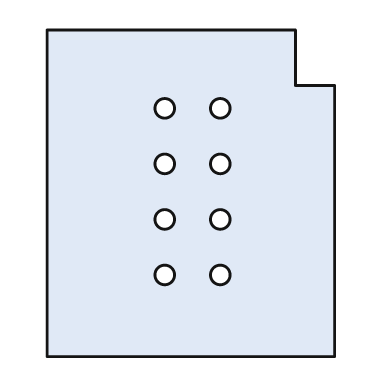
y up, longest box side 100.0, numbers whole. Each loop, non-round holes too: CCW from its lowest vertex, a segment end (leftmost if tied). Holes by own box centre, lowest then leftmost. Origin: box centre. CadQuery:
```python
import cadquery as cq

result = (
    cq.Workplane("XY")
    .moveTo(-44.0, -50.0)
    .lineTo(44.0, -50.0)
    .lineTo(44.0, 33.0)
    .lineTo(32.0, 33.0)
    .lineTo(32.0, 50.0)
    .lineTo(-44.0, 50.0)
    .close()
    .moveTo(-8.0, -25.0)
    .circle(3.0)
    .moveTo(9.0, -25.0)
    .circle(3.0)
    .moveTo(-8.0, -8.0)
    .circle(3.0)
    .moveTo(9.0, -8.0)
    .circle(3.0)
    .moveTo(-8.0, 9.0)
    .circle(3.0)
    .moveTo(9.0, 9.0)
    .circle(3.0)
    .moveTo(-8.0, 26.0)
    .circle(3.0)
    .moveTo(9.0, 26.0)
    .circle(3.0)
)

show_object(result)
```